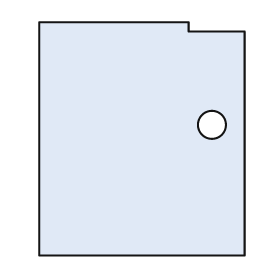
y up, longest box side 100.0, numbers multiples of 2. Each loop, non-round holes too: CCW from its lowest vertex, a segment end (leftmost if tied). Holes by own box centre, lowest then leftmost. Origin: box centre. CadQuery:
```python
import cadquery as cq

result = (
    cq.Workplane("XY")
    .moveTo(-44.0, -50.0)
    .lineTo(44.0, -50.0)
    .lineTo(44.0, 46.0)
    .lineTo(20.0, 46.0)
    .lineTo(20.0, 50.0)
    .lineTo(-44.0, 50.0)
    .close()
    .moveTo(30.0, 6.0)
    .circle(6.0)
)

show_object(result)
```